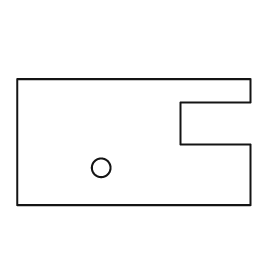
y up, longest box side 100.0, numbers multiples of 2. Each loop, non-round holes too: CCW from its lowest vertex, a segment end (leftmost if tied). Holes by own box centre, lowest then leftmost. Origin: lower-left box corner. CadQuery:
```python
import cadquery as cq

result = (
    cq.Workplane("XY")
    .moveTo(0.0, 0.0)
    .lineTo(100.0, 0.0)
    .lineTo(100.0, 26.0)
    .lineTo(70.0, 26.0)
    .lineTo(70.0, 44.0)
    .lineTo(100.0, 44.0)
    .lineTo(100.0, 54.0)
    .lineTo(0.0, 54.0)
    .close()
    .moveTo(36.0, 16.0)
    .circle(4.0)
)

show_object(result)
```